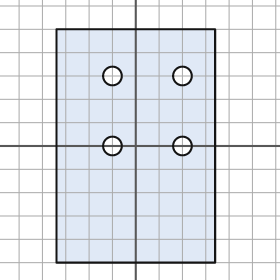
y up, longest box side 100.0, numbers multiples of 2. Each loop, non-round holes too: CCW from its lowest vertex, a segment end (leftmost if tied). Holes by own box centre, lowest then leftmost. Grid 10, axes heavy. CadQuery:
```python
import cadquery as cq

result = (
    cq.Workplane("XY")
    .moveTo(-34.0, -50.0)
    .lineTo(34.0, -50.0)
    .lineTo(34.0, 50.0)
    .lineTo(-34.0, 50.0)
    .close()
    .moveTo(-10.0, 0.0)
    .circle(4.0)
    .moveTo(20.0, 0.0)
    .circle(4.0)
    .moveTo(-10.0, 30.0)
    .circle(4.0)
    .moveTo(20.0, 30.0)
    .circle(4.0)
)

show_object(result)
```